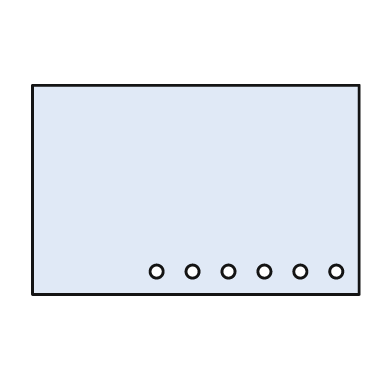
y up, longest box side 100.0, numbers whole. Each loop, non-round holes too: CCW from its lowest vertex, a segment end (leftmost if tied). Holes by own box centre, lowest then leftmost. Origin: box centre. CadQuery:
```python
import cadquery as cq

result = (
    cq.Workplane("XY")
    .moveTo(-50.0, -32.0)
    .lineTo(50.0, -32.0)
    .lineTo(50.0, 32.0)
    .lineTo(-50.0, 32.0)
    .close()
    .moveTo(-12.0, -25.0)
    .circle(2.0)
    .moveTo(-1.0, -25.0)
    .circle(2.0)
    .moveTo(10.0, -25.0)
    .circle(2.0)
    .moveTo(21.0, -25.0)
    .circle(2.0)
    .moveTo(32.0, -25.0)
    .circle(2.0)
    .moveTo(43.0, -25.0)
    .circle(2.0)
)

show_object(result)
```